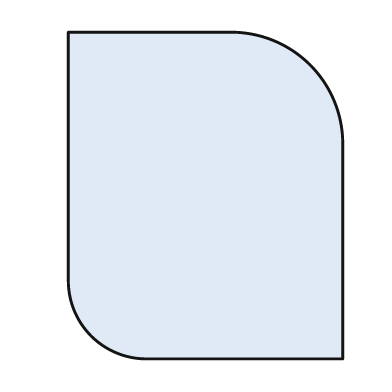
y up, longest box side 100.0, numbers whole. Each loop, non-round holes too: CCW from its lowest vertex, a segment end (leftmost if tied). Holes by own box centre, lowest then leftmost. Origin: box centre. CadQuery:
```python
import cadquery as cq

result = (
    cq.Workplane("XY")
    .moveTo(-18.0, -50.0)
    .lineTo(42.0, -50.0)
    .lineTo(42.0, 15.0)
    .threePointArc((32.0, 40.0), (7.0, 50.0))
    .lineTo(-42.0, 50.0)
    .lineTo(-42.0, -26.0)
    .threePointArc((-35.0, -43.0), (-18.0, -50.0))
    .close()
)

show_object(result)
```